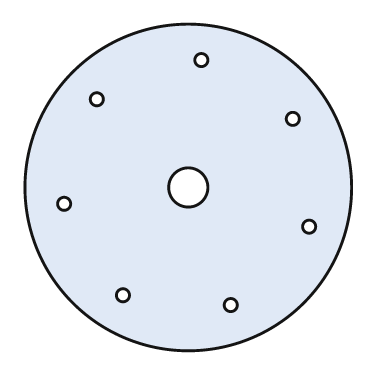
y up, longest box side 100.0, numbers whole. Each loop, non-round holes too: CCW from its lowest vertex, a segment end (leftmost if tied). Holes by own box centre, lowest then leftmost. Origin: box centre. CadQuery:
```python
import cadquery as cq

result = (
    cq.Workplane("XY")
    .moveTo(0.0, 0.0)
    .circle(50.0)
    .moveTo(13.0, -36.0)
    .circle(2.0)
    .moveTo(-20.0, -33.0)
    .circle(2.0)
    .moveTo(37.0, -12.0)
    .circle(2.0)
    .moveTo(-38.0, -5.0)
    .circle(2.0)
    .moveTo(0.0, 0.0)
    .circle(6.0)
    .moveTo(32.0, 21.0)
    .circle(2.0)
    .moveTo(-28.0, 27.0)
    .circle(2.0)
    .moveTo(4.0, 39.0)
    .circle(2.0)
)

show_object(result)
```